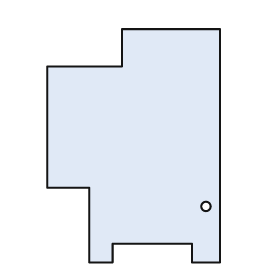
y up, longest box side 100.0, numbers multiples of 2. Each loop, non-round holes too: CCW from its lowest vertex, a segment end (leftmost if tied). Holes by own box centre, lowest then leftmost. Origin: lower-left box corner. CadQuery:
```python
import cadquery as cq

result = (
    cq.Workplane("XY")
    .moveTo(18.0, 0.0)
    .lineTo(28.0, 0.0)
    .lineTo(28.0, 8.0)
    .lineTo(62.0, 8.0)
    .lineTo(62.0, 0.0)
    .lineTo(74.0, 0.0)
    .lineTo(74.0, 100.0)
    .lineTo(32.0, 100.0)
    .lineTo(32.0, 84.0)
    .lineTo(0.0, 84.0)
    .lineTo(0.0, 32.0)
    .lineTo(18.0, 32.0)
    .close()
    .moveTo(68.0, 24.0)
    .circle(2.0)
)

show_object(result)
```